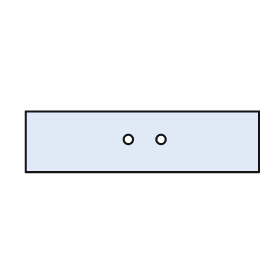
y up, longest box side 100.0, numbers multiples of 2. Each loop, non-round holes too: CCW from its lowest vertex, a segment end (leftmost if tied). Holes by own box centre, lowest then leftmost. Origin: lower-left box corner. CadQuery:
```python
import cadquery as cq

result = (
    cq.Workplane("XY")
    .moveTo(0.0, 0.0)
    .lineTo(100.0, 0.0)
    .lineTo(100.0, 26.0)
    .lineTo(0.0, 26.0)
    .close()
    .moveTo(44.0, 14.0)
    .circle(2.0)
    .moveTo(58.0, 14.0)
    .circle(2.0)
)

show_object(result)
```